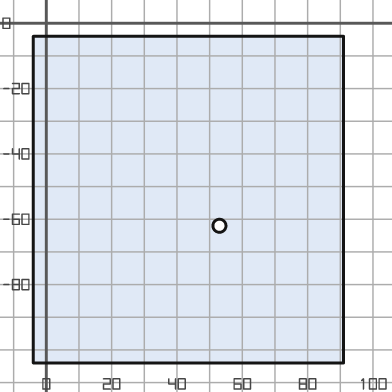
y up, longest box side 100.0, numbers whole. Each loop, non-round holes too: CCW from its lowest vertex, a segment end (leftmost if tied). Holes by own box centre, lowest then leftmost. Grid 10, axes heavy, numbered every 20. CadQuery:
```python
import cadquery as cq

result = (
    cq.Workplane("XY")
    .moveTo(-4.0, -104.0)
    .lineTo(91.0, -104.0)
    .lineTo(91.0, -4.0)
    .lineTo(-4.0, -4.0)
    .close()
    .moveTo(53.0, -62.0)
    .circle(2.0)
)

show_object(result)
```